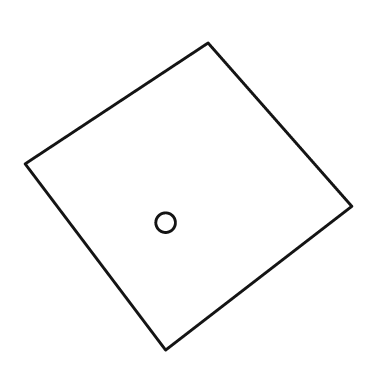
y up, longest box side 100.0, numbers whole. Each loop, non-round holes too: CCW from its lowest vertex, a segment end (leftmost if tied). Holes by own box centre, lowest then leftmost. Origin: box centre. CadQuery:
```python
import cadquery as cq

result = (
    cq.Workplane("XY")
    .moveTo(-7.0, -47.0)
    .lineTo(50.0, -3.0)
    .lineTo(6.0, 47.0)
    .lineTo(-50.0, 10.0)
    .close()
    .moveTo(-7.0, -8.0)
    .circle(3.0)
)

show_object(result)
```